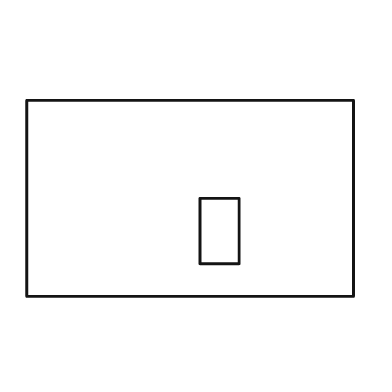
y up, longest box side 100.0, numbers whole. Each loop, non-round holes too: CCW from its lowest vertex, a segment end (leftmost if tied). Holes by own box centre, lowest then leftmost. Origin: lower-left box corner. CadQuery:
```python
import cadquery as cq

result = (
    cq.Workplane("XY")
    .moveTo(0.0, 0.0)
    .lineTo(100.0, 0.0)
    .lineTo(100.0, 60.0)
    .lineTo(0.0, 60.0)
    .close()
    .moveTo(53.0, 10.0)
    .lineTo(65.0, 10.0)
    .lineTo(65.0, 30.0)
    .lineTo(53.0, 30.0)
    .close()
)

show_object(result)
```